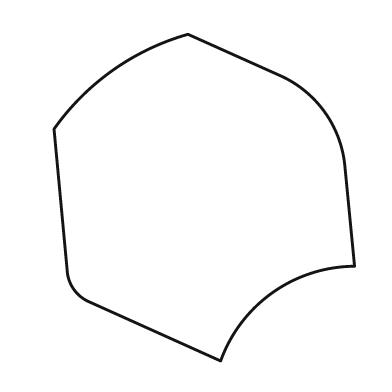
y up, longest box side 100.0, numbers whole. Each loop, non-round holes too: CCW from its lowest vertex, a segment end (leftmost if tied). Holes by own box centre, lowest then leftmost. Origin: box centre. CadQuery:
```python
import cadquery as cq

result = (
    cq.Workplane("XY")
    .moveTo(5.0, -50.0)
    .threePointArc((21.0, -29.0), (46.0, -21.0))
    .lineTo(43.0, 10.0)
    .threePointArc((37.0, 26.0), (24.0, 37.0))
    .lineTo(-5.0, 50.0)
    .threePointArc((-28.0, 39.0), (-46.0, 21.0))
    .lineTo(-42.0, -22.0)
    .threePointArc((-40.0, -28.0), (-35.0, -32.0))
    .close()
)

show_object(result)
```